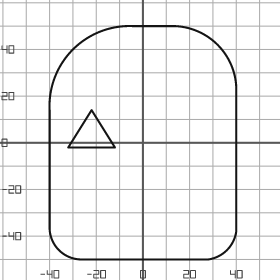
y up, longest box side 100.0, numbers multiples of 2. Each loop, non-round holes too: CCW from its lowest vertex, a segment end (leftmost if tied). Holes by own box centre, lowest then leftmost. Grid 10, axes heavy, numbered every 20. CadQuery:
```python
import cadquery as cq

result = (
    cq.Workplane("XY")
    .moveTo(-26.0, -50.0)
    .lineTo(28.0, -50.0)
    .threePointArc((36.0, -46.0), (40.0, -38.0))
    .lineTo(40.0, 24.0)
    .threePointArc((32.0, 42.0), (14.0, 50.0))
    .lineTo(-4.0, 50.0)
    .threePointArc((-30.0, 40.0), (-40.0, 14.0))
    .lineTo(-40.0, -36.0)
    .threePointArc((-36.0, -46.0), (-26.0, -50.0))
    .close()
    .moveTo(-32.0, -2.0)
    .lineTo(-12.0, -2.0)
    .lineTo(-22.0, 14.0)
    .close()
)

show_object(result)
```